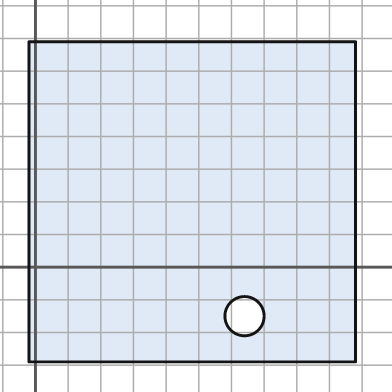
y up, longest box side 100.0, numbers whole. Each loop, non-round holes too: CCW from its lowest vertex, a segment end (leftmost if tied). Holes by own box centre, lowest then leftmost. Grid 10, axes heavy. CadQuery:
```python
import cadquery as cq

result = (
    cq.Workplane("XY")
    .moveTo(-2.0, -29.0)
    .lineTo(98.0, -29.0)
    .lineTo(98.0, 69.0)
    .lineTo(-2.0, 69.0)
    .close()
    .moveTo(64.0, -15.0)
    .circle(6.0)
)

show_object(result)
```